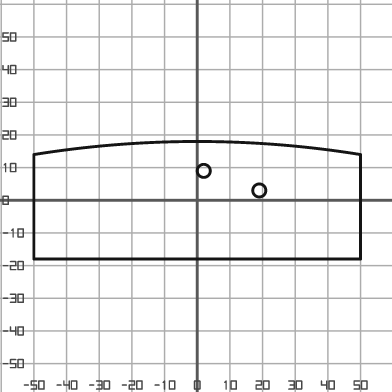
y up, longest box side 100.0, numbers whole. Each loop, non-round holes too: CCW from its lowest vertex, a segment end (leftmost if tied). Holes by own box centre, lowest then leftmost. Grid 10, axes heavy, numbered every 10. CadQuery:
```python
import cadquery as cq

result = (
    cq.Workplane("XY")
    .moveTo(-50.0, -18.0)
    .lineTo(50.0, -18.0)
    .lineTo(50.0, 14.0)
    .threePointArc((0.0, 18.0), (-50.0, 14.0))
    .close()
    .moveTo(19.0, 3.0)
    .circle(2.0)
    .moveTo(2.0, 9.0)
    .circle(2.0)
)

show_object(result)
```